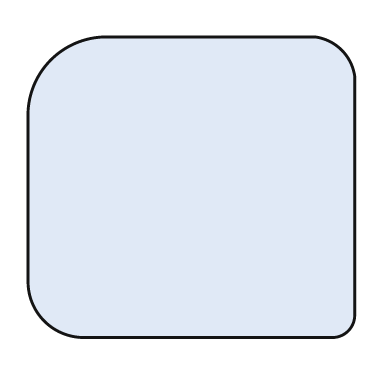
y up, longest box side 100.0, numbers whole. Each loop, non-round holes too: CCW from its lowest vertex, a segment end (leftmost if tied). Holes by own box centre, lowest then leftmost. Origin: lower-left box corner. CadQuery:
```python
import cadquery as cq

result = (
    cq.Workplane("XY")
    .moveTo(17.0, 0.0)
    .lineTo(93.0, 0.0)
    .threePointArc((98.0, 2.0), (100.0, 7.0))
    .lineTo(100.0, 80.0)
    .threePointArc((96.0, 88.0), (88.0, 92.0))
    .lineTo(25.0, 92.0)
    .threePointArc((7.0, 85.0), (0.0, 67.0))
    .lineTo(0.0, 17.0)
    .threePointArc((5.0, 5.0), (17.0, 0.0))
    .close()
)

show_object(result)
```